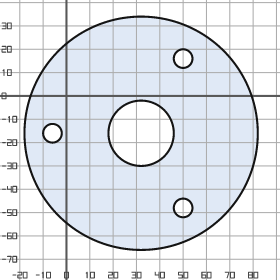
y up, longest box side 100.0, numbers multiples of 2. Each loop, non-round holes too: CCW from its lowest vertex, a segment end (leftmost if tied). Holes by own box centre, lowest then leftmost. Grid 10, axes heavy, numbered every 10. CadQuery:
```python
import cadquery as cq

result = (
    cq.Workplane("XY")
    .moveTo(32.0, -16.0)
    .circle(50.0)
    .moveTo(50.0, -48.0)
    .circle(4.0)
    .moveTo(-6.0, -16.0)
    .circle(4.0)
    .moveTo(32.0, -16.0)
    .circle(14.0)
    .moveTo(50.0, 16.0)
    .circle(4.0)
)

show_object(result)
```